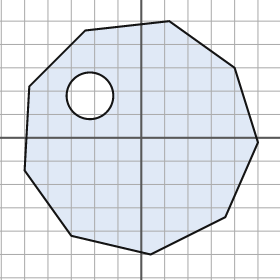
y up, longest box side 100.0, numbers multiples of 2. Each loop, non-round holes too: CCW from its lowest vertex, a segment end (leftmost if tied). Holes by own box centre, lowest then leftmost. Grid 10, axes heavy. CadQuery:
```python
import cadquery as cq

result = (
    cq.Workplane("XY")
    .moveTo(4.0, -50.0)
    .lineTo(36.0, -34.0)
    .lineTo(50.0, -2.0)
    .lineTo(40.0, 30.0)
    .lineTo(12.0, 50.0)
    .lineTo(-24.0, 46.0)
    .lineTo(-48.0, 22.0)
    .lineTo(-50.0, -14.0)
    .lineTo(-30.0, -42.0)
    .close()
    .moveTo(-22.0, 18.0)
    .circle(10.0)
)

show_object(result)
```